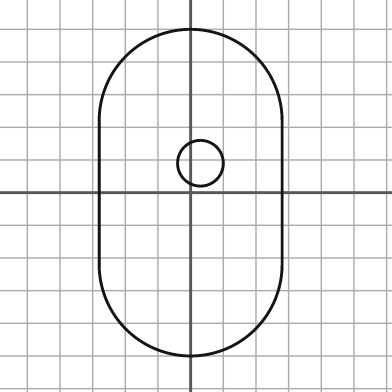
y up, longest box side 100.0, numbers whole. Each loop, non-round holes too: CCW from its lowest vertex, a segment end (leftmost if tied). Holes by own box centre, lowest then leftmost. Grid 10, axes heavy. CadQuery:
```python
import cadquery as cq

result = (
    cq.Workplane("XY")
    .moveTo(-28.0, -22.0)
    .threePointArc((0.0, -50.0), (28.0, -22.0))
    .lineTo(28.0, 22.0)
    .threePointArc((0.0, 50.0), (-28.0, 22.0))
    .close()
    .moveTo(3.0, 9.0)
    .circle(7.0)
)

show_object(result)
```